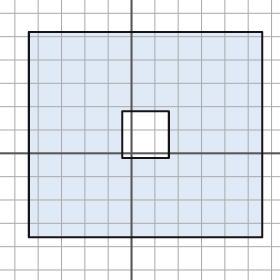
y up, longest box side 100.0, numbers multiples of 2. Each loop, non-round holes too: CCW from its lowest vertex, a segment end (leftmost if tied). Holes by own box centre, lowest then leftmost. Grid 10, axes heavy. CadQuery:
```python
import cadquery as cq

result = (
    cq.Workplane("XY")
    .moveTo(-44.0, -36.0)
    .lineTo(56.0, -36.0)
    .lineTo(56.0, 52.0)
    .lineTo(-44.0, 52.0)
    .close()
    .moveTo(-4.0, -2.0)
    .lineTo(16.0, -2.0)
    .lineTo(16.0, 18.0)
    .lineTo(-4.0, 18.0)
    .close()
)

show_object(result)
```